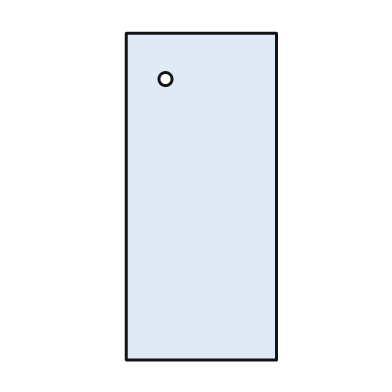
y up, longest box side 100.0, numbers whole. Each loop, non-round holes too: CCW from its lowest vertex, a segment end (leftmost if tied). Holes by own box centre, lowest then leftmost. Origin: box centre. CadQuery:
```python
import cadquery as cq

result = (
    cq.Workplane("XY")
    .moveTo(-23.0, -50.0)
    .lineTo(23.0, -50.0)
    .lineTo(23.0, 50.0)
    .lineTo(-23.0, 50.0)
    .close()
    .moveTo(-11.0, 36.0)
    .circle(2.0)
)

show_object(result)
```